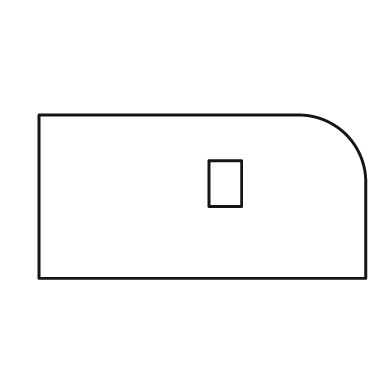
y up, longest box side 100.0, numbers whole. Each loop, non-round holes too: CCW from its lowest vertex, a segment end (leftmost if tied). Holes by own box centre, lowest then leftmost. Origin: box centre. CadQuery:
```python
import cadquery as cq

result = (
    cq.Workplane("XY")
    .moveTo(-50.0, -25.0)
    .lineTo(50.0, -25.0)
    .lineTo(50.0, 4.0)
    .threePointArc((44.0, 19.0), (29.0, 25.0))
    .lineTo(-50.0, 25.0)
    .close()
    .moveTo(2.0, -3.0)
    .lineTo(12.0, -3.0)
    .lineTo(12.0, 11.0)
    .lineTo(2.0, 11.0)
    .close()
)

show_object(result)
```